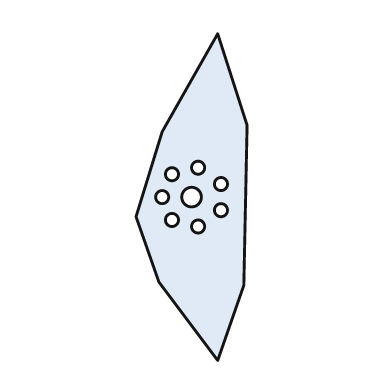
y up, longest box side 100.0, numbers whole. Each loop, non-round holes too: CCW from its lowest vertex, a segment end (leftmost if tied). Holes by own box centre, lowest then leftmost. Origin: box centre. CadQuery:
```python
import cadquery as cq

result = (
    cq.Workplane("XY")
    .moveTo(8.0, -50.0)
    .lineTo(16.0, -27.0)
    .lineTo(17.0, 22.0)
    .lineTo(8.0, 50.0)
    .lineTo(-9.0, 20.0)
    .lineTo(-17.0, -6.0)
    .lineTo(-10.0, -26.0)
    .close()
    .moveTo(2.0, -9.0)
    .circle(2.0)
    .moveTo(-6.0, -7.0)
    .circle(2.0)
    .moveTo(9.0, -4.0)
    .circle(2.0)
    .moveTo(-9.0, 0.0)
    .circle(2.0)
    .moveTo(0.0, 0.0)
    .circle(3.0)
    .moveTo(9.0, 4.0)
    .circle(2.0)
    .moveTo(-6.0, 7.0)
    .circle(2.0)
    .moveTo(2.0, 9.0)
    .circle(2.0)
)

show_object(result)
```